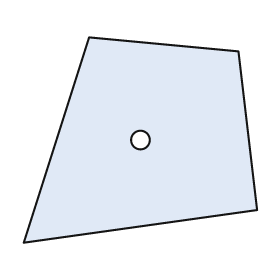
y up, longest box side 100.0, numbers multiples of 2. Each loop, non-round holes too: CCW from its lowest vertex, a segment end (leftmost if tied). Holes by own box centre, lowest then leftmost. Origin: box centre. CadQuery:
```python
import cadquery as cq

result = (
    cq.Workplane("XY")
    .moveTo(-50.0, -44.0)
    .lineTo(50.0, -30.0)
    .lineTo(42.0, 38.0)
    .lineTo(-22.0, 44.0)
    .close()
    .moveTo(0.0, 0.0)
    .circle(4.0)
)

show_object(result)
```